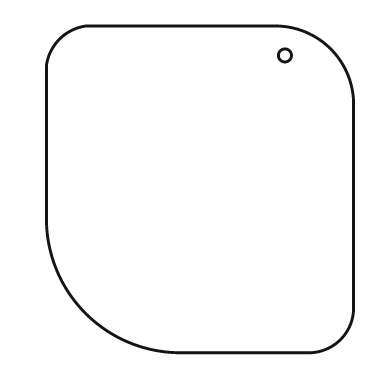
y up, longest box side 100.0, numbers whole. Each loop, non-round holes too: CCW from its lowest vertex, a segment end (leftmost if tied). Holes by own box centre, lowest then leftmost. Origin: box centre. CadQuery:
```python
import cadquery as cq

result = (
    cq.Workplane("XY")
    .moveTo(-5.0, -50.0)
    .lineTo(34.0, -50.0)
    .threePointArc((43.0, -46.0), (47.0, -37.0))
    .lineTo(47.0, 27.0)
    .threePointArc((40.0, 43.0), (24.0, 50.0))
    .lineTo(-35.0, 50.0)
    .threePointArc((-43.0, 46.0), (-47.0, 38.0))
    .lineTo(-47.0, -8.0)
    .threePointArc((-35.0, -38.0), (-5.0, -50.0))
    .close()
    .moveTo(26.0, 41.0)
    .circle(2.0)
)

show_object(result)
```